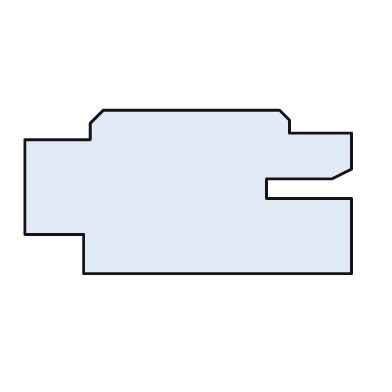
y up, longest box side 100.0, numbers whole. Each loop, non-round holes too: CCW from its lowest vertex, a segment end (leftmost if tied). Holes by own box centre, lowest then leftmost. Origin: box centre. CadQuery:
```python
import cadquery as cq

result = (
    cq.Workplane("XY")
    .moveTo(-32.0, -25.0)
    .lineTo(50.0, -25.0)
    .lineTo(50.0, -2.0)
    .lineTo(24.0, -2.0)
    .lineTo(24.0, 4.0)
    .lineTo(44.0, 4.0)
    .lineTo(50.0, 7.0)
    .lineTo(50.0, 18.0)
    .lineTo(31.0, 18.0)
    .lineTo(31.0, 22.0)
    .lineTo(28.0, 25.0)
    .lineTo(-26.0, 25.0)
    .lineTo(-30.0, 21.0)
    .lineTo(-30.0, 16.0)
    .lineTo(-50.0, 16.0)
    .lineTo(-50.0, -13.0)
    .lineTo(-32.0, -13.0)
    .close()
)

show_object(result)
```